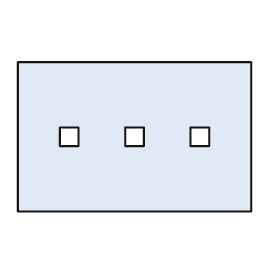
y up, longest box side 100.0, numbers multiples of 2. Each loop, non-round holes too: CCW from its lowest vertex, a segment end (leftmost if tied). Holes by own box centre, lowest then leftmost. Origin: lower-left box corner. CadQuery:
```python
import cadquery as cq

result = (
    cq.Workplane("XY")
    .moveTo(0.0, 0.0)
    .lineTo(100.0, 0.0)
    .lineTo(100.0, 64.0)
    .lineTo(0.0, 64.0)
    .close()
    .moveTo(18.0, 28.0)
    .lineTo(26.0, 28.0)
    .lineTo(26.0, 36.0)
    .lineTo(18.0, 36.0)
    .close()
    .moveTo(46.0, 28.0)
    .lineTo(54.0, 28.0)
    .lineTo(54.0, 36.0)
    .lineTo(46.0, 36.0)
    .close()
    .moveTo(74.0, 28.0)
    .lineTo(82.0, 28.0)
    .lineTo(82.0, 36.0)
    .lineTo(74.0, 36.0)
    .close()
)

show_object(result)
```